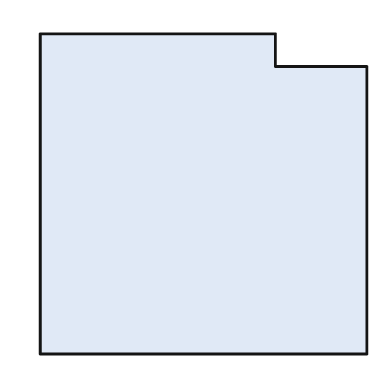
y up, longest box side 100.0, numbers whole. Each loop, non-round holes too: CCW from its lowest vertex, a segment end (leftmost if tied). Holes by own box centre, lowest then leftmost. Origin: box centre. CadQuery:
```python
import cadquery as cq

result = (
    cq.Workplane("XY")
    .moveTo(-50.0, -49.0)
    .lineTo(50.0, -49.0)
    .lineTo(50.0, 39.0)
    .lineTo(22.0, 39.0)
    .lineTo(22.0, 49.0)
    .lineTo(-50.0, 49.0)
    .close()
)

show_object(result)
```